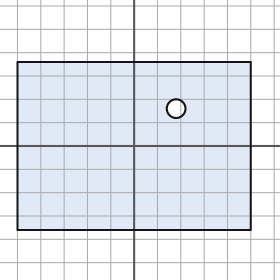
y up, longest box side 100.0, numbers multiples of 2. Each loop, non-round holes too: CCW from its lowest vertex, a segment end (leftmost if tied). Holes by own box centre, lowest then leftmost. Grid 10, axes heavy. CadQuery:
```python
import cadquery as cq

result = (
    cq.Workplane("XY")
    .moveTo(-50.0, -36.0)
    .lineTo(50.0, -36.0)
    .lineTo(50.0, 36.0)
    .lineTo(-50.0, 36.0)
    .close()
    .moveTo(18.0, 16.0)
    .circle(4.0)
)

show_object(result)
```